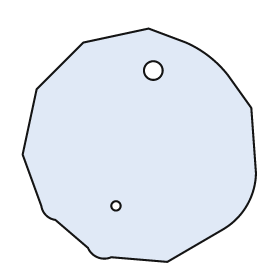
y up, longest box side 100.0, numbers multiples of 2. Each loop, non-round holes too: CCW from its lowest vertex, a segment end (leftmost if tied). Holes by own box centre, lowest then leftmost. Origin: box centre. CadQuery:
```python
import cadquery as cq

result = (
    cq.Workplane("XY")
    .moveTo(12.0, -50.0)
    .lineTo(36.0, -36.0)
    .threePointArc((46.0, -26.0), (50.0, -12.0))
    .lineTo(48.0, 16.0)
    .lineTo(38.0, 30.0)
    .threePointArc((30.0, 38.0), (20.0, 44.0))
    .lineTo(4.0, 50.0)
    .lineTo(-24.0, 44.0)
    .lineTo(-44.0, 24.0)
    .lineTo(-50.0, -4.0)
    .lineTo(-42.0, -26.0)
    .threePointArc((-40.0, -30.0), (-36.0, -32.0))
    .lineTo(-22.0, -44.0)
    .threePointArc((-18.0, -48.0), (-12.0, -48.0))
    .close()
    .moveTo(-10.0, -26.0)
    .circle(2.0)
    .moveTo(6.0, 32.0)
    .circle(4.0)
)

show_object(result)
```